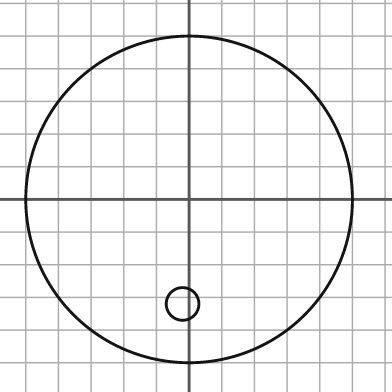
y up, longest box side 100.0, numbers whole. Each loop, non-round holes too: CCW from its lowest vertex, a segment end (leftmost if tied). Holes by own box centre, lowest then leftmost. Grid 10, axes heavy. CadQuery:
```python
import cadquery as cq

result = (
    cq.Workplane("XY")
    .moveTo(0.0, 0.0)
    .circle(50.0)
    .moveTo(-2.0, -32.0)
    .circle(5.0)
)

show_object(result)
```